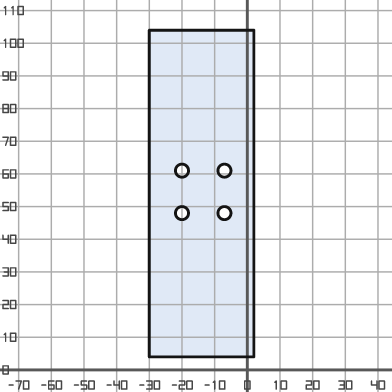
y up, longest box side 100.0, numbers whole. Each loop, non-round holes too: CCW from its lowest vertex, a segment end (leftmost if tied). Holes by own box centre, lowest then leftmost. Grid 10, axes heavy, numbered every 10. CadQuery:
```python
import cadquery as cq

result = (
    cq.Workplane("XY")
    .moveTo(-30.0, 4.0)
    .lineTo(2.0, 4.0)
    .lineTo(2.0, 104.0)
    .lineTo(-30.0, 104.0)
    .close()
    .moveTo(-20.0, 48.0)
    .circle(2.0)
    .moveTo(-7.0, 48.0)
    .circle(2.0)
    .moveTo(-20.0, 61.0)
    .circle(2.0)
    .moveTo(-7.0, 61.0)
    .circle(2.0)
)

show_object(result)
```